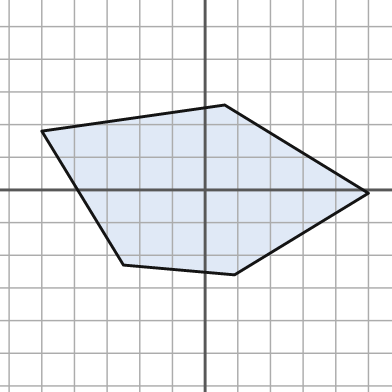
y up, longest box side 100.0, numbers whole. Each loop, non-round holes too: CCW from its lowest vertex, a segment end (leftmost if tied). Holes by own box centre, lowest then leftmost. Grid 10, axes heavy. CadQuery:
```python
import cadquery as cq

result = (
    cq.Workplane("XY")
    .moveTo(9.0, -26.0)
    .lineTo(50.0, -1.0)
    .lineTo(6.0, 26.0)
    .lineTo(-50.0, 18.0)
    .lineTo(-25.0, -23.0)
    .close()
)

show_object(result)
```